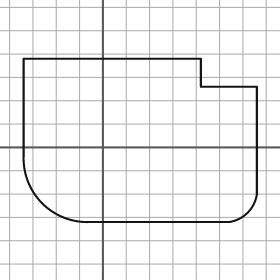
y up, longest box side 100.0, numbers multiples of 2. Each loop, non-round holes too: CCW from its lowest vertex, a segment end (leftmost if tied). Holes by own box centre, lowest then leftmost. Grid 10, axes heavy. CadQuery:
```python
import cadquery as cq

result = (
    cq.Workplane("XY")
    .moveTo(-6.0, -32.0)
    .lineTo(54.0, -32.0)
    .threePointArc((62.0, -28.0), (66.0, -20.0))
    .lineTo(66.0, 26.0)
    .lineTo(42.0, 26.0)
    .lineTo(42.0, 38.0)
    .lineTo(-34.0, 38.0)
    .lineTo(-34.0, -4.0)
    .threePointArc((-26.0, -24.0), (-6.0, -32.0))
    .close()
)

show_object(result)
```